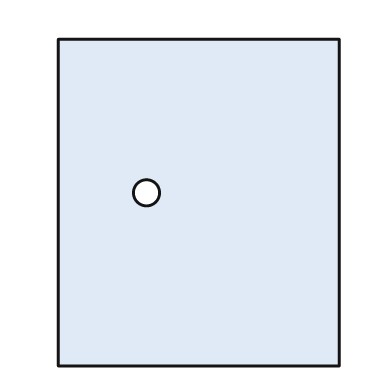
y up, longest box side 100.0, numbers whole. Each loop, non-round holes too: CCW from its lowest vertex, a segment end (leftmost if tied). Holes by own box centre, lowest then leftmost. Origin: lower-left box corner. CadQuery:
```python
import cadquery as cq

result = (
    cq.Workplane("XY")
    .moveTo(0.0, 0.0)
    .lineTo(86.0, 0.0)
    .lineTo(86.0, 100.0)
    .lineTo(0.0, 100.0)
    .close()
    .moveTo(27.0, 53.0)
    .circle(4.0)
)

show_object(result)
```